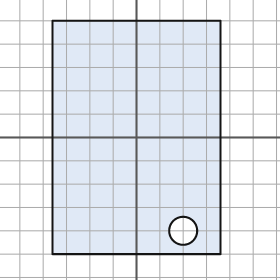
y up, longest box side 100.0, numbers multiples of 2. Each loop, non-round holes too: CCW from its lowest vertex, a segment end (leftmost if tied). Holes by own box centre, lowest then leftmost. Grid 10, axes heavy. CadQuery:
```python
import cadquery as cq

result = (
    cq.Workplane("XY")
    .moveTo(-36.0, -50.0)
    .lineTo(36.0, -50.0)
    .lineTo(36.0, 50.0)
    .lineTo(-36.0, 50.0)
    .close()
    .moveTo(20.0, -40.0)
    .circle(6.0)
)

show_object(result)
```